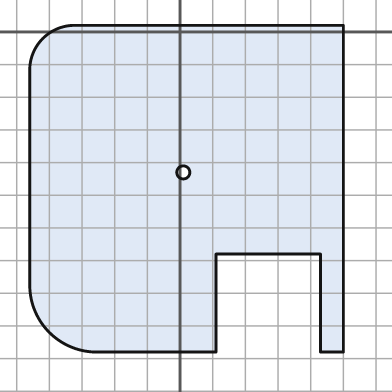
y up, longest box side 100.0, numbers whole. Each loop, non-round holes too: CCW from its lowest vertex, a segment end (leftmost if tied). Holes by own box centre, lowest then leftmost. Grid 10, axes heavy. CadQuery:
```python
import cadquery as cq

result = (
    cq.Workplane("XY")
    .moveTo(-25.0, -98.0)
    .lineTo(11.0, -98.0)
    .lineTo(11.0, -68.0)
    .lineTo(43.0, -68.0)
    .lineTo(43.0, -98.0)
    .lineTo(50.0, -98.0)
    .lineTo(50.0, 2.0)
    .lineTo(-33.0, 2.0)
    .threePointArc((-42.0, -2.0), (-46.0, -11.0))
    .lineTo(-46.0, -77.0)
    .threePointArc((-40.0, -92.0), (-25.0, -98.0))
    .close()
    .moveTo(1.0, -43.0)
    .circle(2.0)
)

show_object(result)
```